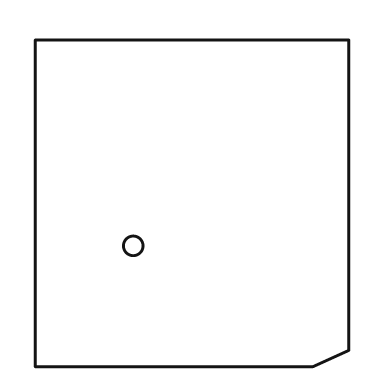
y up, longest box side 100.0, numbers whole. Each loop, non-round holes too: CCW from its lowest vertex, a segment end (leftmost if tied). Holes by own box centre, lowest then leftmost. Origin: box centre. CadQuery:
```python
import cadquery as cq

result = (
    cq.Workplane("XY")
    .moveTo(-48.0, -50.0)
    .lineTo(37.0, -50.0)
    .lineTo(48.0, -45.0)
    .lineTo(48.0, 50.0)
    .lineTo(-48.0, 50.0)
    .close()
    .moveTo(-18.0, -13.0)
    .circle(3.0)
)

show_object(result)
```